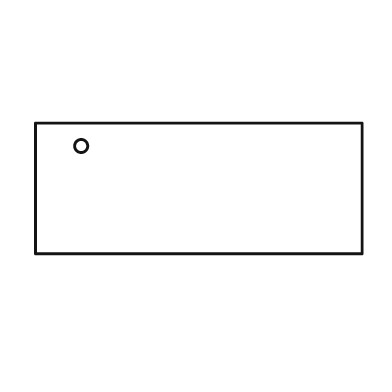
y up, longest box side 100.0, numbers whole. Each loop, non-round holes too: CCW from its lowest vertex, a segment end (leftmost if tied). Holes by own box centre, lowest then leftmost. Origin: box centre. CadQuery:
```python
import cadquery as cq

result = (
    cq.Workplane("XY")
    .moveTo(-50.0, -20.0)
    .lineTo(50.0, -20.0)
    .lineTo(50.0, 20.0)
    .lineTo(-50.0, 20.0)
    .close()
    .moveTo(-36.0, 13.0)
    .circle(2.0)
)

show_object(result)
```